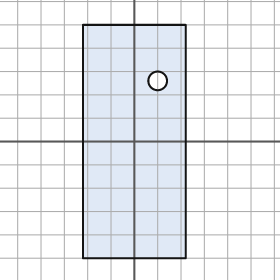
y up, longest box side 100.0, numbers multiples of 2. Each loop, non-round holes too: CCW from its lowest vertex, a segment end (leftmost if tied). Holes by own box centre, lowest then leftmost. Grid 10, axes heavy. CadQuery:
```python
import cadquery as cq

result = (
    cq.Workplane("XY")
    .moveTo(-22.0, -50.0)
    .lineTo(22.0, -50.0)
    .lineTo(22.0, 50.0)
    .lineTo(-22.0, 50.0)
    .close()
    .moveTo(10.0, 26.0)
    .circle(4.0)
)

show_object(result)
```